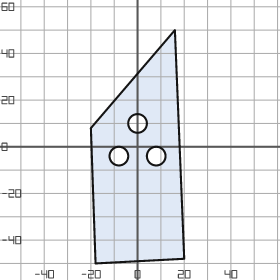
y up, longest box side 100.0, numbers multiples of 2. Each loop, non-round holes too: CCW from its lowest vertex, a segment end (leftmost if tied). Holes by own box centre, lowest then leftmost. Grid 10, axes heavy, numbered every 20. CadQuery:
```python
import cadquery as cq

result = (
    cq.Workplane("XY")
    .moveTo(-18.0, -50.0)
    .lineTo(20.0, -48.0)
    .lineTo(16.0, 50.0)
    .lineTo(-20.0, 8.0)
    .close()
    .moveTo(-8.0, -4.0)
    .circle(4.0)
    .moveTo(8.0, -4.0)
    .circle(4.0)
    .moveTo(0.0, 10.0)
    .circle(4.0)
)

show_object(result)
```